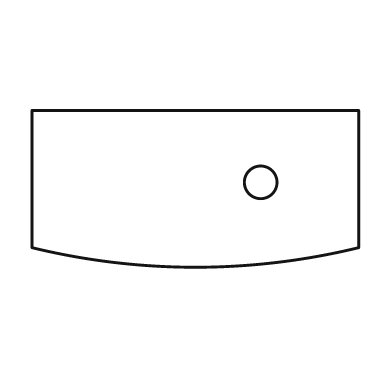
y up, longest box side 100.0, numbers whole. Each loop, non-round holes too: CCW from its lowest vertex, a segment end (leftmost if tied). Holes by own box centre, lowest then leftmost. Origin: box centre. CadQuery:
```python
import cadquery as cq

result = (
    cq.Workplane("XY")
    .moveTo(-50.0, -18.0)
    .threePointArc((0.0, -24.0), (50.0, -18.0))
    .lineTo(50.0, 24.0)
    .lineTo(-50.0, 24.0)
    .close()
    .moveTo(20.0, 2.0)
    .circle(5.0)
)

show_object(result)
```